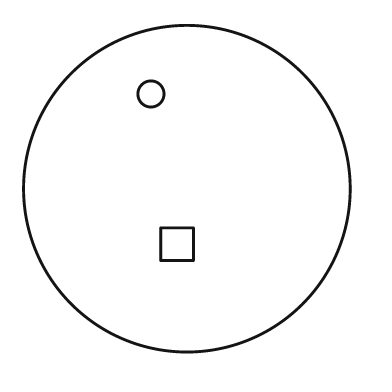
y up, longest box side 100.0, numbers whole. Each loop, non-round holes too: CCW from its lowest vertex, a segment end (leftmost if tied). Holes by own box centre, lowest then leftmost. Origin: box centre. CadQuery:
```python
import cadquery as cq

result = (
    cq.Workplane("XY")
    .moveTo(0.0, 0.0)
    .circle(50.0)
    .moveTo(-8.0, -22.0)
    .lineTo(2.0, -22.0)
    .lineTo(2.0, -12.0)
    .lineTo(-8.0, -12.0)
    .close()
    .moveTo(-11.0, 29.0)
    .circle(4.0)
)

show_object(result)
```